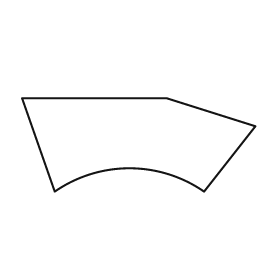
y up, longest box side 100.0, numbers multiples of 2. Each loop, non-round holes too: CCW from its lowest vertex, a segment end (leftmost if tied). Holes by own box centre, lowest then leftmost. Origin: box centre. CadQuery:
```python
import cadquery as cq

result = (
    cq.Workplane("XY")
    .moveTo(-36.0, -20.0)
    .threePointArc((-4.0, -10.0), (28.0, -20.0))
    .lineTo(50.0, 8.0)
    .lineTo(12.0, 20.0)
    .lineTo(-50.0, 20.0)
    .close()
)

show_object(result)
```